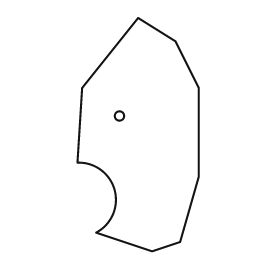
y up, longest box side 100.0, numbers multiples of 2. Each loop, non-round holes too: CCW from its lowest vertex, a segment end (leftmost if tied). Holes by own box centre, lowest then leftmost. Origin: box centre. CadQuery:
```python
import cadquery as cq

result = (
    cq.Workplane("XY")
    .moveTo(6.0, -50.0)
    .lineTo(18.0, -46.0)
    .lineTo(26.0, -18.0)
    .lineTo(26.0, 20.0)
    .lineTo(16.0, 40.0)
    .lineTo(0.0, 50.0)
    .lineTo(-24.0, 20.0)
    .lineTo(-26.0, -12.0)
    .threePointArc((-10.0, -24.0), (-18.0, -42.0))
    .close()
    .moveTo(-8.0, 8.0)
    .circle(2.0)
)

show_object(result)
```